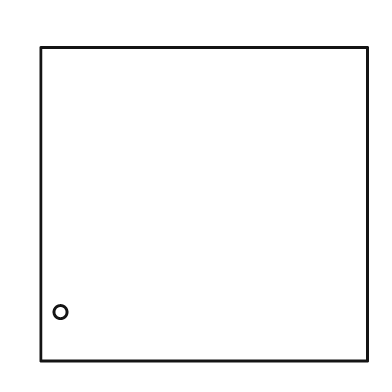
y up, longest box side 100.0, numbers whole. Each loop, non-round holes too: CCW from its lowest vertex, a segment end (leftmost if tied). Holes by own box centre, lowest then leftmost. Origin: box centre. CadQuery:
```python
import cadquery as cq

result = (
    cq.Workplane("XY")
    .moveTo(-50.0, -48.0)
    .lineTo(50.0, -48.0)
    .lineTo(50.0, 48.0)
    .lineTo(-50.0, 48.0)
    .close()
    .moveTo(-44.0, -33.0)
    .circle(2.0)
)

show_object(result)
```